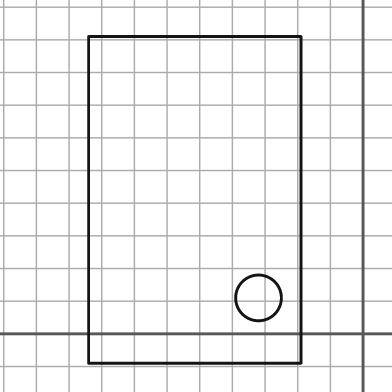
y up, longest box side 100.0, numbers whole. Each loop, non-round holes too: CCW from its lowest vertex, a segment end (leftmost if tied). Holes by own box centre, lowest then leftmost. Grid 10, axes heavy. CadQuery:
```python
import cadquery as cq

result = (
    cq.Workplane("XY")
    .moveTo(-84.0, -9.0)
    .lineTo(-19.0, -9.0)
    .lineTo(-19.0, 91.0)
    .lineTo(-84.0, 91.0)
    .close()
    .moveTo(-32.0, 11.0)
    .circle(7.0)
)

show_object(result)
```